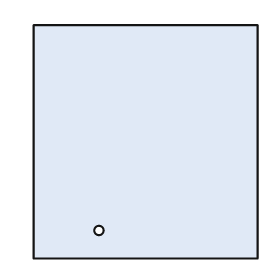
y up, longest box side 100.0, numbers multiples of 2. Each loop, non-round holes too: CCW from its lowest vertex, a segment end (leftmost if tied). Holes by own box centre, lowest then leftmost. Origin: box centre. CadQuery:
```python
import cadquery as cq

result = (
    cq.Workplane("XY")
    .moveTo(-48.0, -50.0)
    .lineTo(48.0, -50.0)
    .lineTo(48.0, 50.0)
    .lineTo(-48.0, 50.0)
    .close()
    .moveTo(-20.0, -38.0)
    .circle(2.0)
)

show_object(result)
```